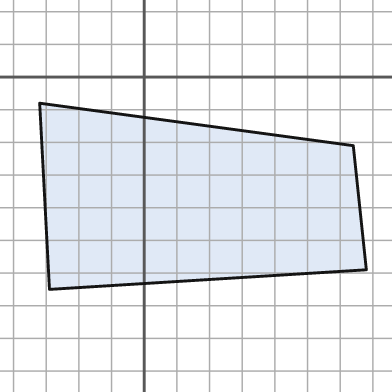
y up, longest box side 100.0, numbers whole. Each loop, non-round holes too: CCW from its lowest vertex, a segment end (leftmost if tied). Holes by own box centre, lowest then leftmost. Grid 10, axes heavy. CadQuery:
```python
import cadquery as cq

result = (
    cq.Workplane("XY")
    .moveTo(-29.0, -65.0)
    .lineTo(68.0, -59.0)
    .lineTo(64.0, -21.0)
    .lineTo(-32.0, -8.0)
    .close()
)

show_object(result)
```